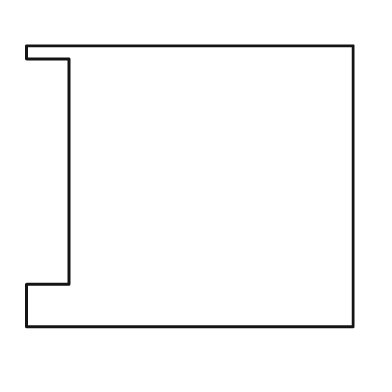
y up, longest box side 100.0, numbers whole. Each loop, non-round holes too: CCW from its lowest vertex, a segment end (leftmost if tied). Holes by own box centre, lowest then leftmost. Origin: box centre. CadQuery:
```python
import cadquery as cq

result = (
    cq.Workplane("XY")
    .moveTo(-50.0, -43.0)
    .lineTo(50.0, -43.0)
    .lineTo(50.0, 43.0)
    .lineTo(-50.0, 43.0)
    .lineTo(-50.0, 39.0)
    .lineTo(-37.0, 39.0)
    .lineTo(-37.0, -30.0)
    .lineTo(-50.0, -30.0)
    .close()
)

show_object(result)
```